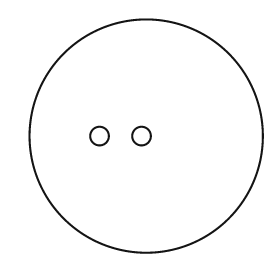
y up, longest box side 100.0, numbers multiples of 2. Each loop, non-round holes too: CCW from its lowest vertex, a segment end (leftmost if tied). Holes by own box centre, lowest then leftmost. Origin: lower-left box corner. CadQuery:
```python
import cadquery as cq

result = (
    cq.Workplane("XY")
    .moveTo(50.0, 50.0)
    .circle(50.0)
    .moveTo(30.0, 50.0)
    .circle(4.0)
    .moveTo(48.0, 50.0)
    .circle(4.0)
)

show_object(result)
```